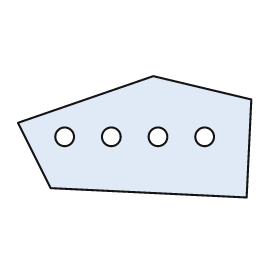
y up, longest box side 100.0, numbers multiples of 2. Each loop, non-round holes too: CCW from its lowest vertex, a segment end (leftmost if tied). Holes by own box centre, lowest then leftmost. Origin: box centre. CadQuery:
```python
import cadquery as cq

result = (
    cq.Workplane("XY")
    .moveTo(48.0, -26.0)
    .lineTo(50.0, 16.0)
    .lineTo(8.0, 26.0)
    .lineTo(-50.0, 6.0)
    .lineTo(-36.0, -22.0)
    .close()
    .moveTo(-30.0, 0.0)
    .circle(4.0)
    .moveTo(-10.0, 0.0)
    .circle(4.0)
    .moveTo(10.0, 0.0)
    .circle(4.0)
    .moveTo(30.0, 0.0)
    .circle(4.0)
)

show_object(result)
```